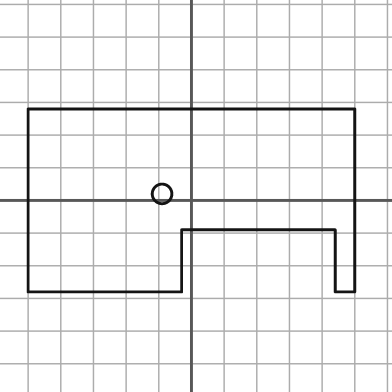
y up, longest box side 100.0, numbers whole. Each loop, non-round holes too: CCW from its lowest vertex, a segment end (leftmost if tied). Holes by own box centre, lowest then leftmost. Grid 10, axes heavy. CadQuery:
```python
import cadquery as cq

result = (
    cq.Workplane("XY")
    .moveTo(-50.0, -28.0)
    .lineTo(-3.0, -28.0)
    .lineTo(-3.0, -9.0)
    .lineTo(44.0, -9.0)
    .lineTo(44.0, -28.0)
    .lineTo(50.0, -28.0)
    .lineTo(50.0, 28.0)
    .lineTo(-50.0, 28.0)
    .close()
    .moveTo(-9.0, 2.0)
    .circle(3.0)
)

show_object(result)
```